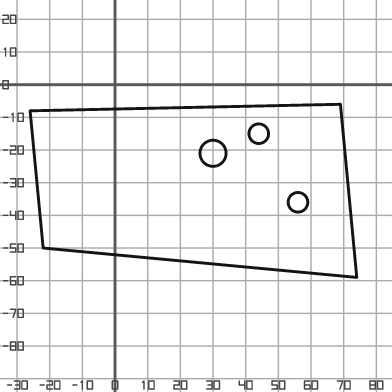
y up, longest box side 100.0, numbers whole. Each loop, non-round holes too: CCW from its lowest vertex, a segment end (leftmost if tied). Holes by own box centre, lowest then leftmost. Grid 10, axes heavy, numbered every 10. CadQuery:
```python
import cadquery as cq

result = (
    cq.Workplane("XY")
    .moveTo(74.0, -59.0)
    .lineTo(69.0, -6.0)
    .lineTo(-26.0, -8.0)
    .lineTo(-22.0, -50.0)
    .close()
    .moveTo(56.0, -36.0)
    .circle(3.0)
    .moveTo(30.0, -21.0)
    .circle(4.0)
    .moveTo(44.0, -15.0)
    .circle(3.0)
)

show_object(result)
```